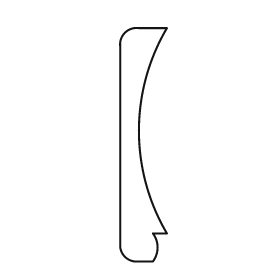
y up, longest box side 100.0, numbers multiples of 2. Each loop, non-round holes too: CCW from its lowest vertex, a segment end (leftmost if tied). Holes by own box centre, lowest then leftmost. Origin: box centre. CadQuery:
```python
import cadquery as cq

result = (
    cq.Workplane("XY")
    .moveTo(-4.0, -50.0)
    .lineTo(4.0, -50.0)
    .threePointArc((6.0, -44.0), (4.0, -38.0))
    .lineTo(10.0, -38.0)
    .threePointArc((-2.0, 6.0), (10.0, 50.0))
    .lineTo(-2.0, 50.0)
    .threePointArc((-8.0, 48.0), (-10.0, 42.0))
    .lineTo(-10.0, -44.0)
    .threePointArc((-8.0, -48.0), (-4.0, -50.0))
    .close()
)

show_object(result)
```